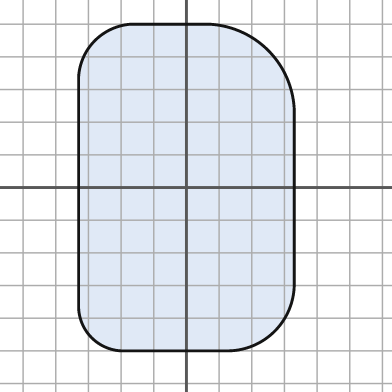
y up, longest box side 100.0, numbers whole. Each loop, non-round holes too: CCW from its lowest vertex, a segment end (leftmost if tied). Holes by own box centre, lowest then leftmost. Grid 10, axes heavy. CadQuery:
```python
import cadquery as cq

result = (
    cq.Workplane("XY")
    .moveTo(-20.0, -50.0)
    .lineTo(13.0, -50.0)
    .threePointArc((27.0, -44.0), (33.0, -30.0))
    .lineTo(33.0, 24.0)
    .threePointArc((25.0, 42.0), (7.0, 50.0))
    .lineTo(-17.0, 50.0)
    .threePointArc((-28.0, 45.0), (-33.0, 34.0))
    .lineTo(-33.0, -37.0)
    .threePointArc((-29.0, -46.0), (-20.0, -50.0))
    .close()
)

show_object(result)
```